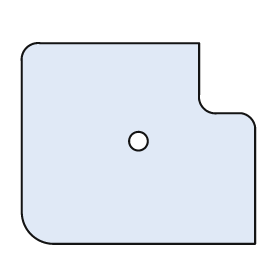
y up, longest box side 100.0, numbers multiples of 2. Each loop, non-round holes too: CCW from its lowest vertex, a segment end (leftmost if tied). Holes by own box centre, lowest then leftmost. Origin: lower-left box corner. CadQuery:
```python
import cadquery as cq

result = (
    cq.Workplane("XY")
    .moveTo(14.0, 0.0)
    .lineTo(100.0, 0.0)
    .lineTo(100.0, 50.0)
    .threePointArc((98.0, 54.0), (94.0, 56.0))
    .lineTo(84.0, 56.0)
    .threePointArc((78.0, 58.0), (76.0, 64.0))
    .lineTo(76.0, 86.0)
    .lineTo(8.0, 86.0)
    .threePointArc((2.0, 84.0), (0.0, 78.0))
    .lineTo(0.0, 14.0)
    .threePointArc((4.0, 4.0), (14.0, 0.0))
    .close()
    .moveTo(50.0, 44.0)
    .circle(4.0)
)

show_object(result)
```